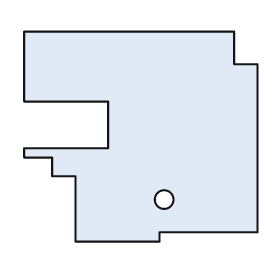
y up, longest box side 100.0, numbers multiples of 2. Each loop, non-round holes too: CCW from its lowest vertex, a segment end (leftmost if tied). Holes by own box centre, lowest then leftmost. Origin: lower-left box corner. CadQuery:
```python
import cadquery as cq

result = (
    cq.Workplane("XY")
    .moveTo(22.0, 0.0)
    .lineTo(58.0, 0.0)
    .lineTo(58.0, 4.0)
    .lineTo(100.0, 4.0)
    .lineTo(100.0, 76.0)
    .lineTo(90.0, 76.0)
    .lineTo(90.0, 90.0)
    .lineTo(0.0, 90.0)
    .lineTo(0.0, 60.0)
    .lineTo(36.0, 60.0)
    .lineTo(36.0, 40.0)
    .lineTo(0.0, 40.0)
    .lineTo(0.0, 36.0)
    .lineTo(12.0, 36.0)
    .lineTo(12.0, 28.0)
    .lineTo(22.0, 28.0)
    .close()
    .moveTo(60.0, 18.0)
    .circle(4.0)
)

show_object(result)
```